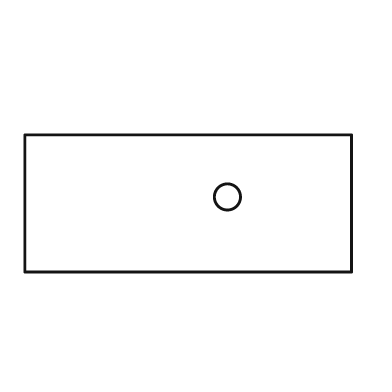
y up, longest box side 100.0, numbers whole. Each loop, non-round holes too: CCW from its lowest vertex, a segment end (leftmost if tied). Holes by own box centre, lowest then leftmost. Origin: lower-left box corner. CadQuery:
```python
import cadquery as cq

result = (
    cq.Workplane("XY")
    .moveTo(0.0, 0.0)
    .lineTo(100.0, 0.0)
    .lineTo(100.0, 42.0)
    .lineTo(0.0, 42.0)
    .close()
    .moveTo(62.0, 23.0)
    .circle(4.0)
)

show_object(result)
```